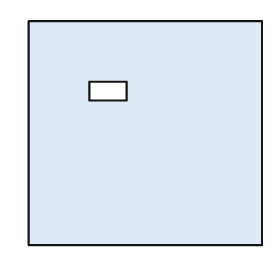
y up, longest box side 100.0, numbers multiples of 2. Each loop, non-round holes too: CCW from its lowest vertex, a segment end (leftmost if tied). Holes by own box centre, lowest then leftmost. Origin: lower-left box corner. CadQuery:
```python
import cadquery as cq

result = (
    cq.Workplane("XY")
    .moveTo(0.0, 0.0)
    .lineTo(100.0, 0.0)
    .lineTo(100.0, 96.0)
    .lineTo(0.0, 96.0)
    .close()
    .moveTo(26.0, 62.0)
    .lineTo(42.0, 62.0)
    .lineTo(42.0, 70.0)
    .lineTo(26.0, 70.0)
    .close()
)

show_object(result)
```